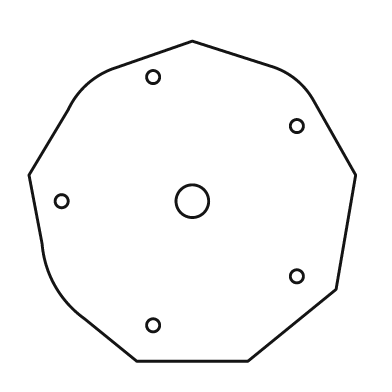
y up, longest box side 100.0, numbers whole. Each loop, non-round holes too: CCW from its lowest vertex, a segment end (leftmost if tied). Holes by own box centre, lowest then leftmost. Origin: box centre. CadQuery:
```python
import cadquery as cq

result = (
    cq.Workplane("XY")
    .moveTo(-17.0, -49.0)
    .lineTo(17.0, -49.0)
    .lineTo(44.0, -27.0)
    .lineTo(50.0, 8.0)
    .lineTo(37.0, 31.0)
    .threePointArc((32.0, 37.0), (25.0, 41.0))
    .lineTo(0.0, 49.0)
    .lineTo(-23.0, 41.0)
    .threePointArc((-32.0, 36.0), (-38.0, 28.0))
    .lineTo(-50.0, 8.0)
    .lineTo(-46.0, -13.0)
    .threePointArc((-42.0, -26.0), (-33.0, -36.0))
    .close()
    .moveTo(-12.0, -38.0)
    .circle(2.0)
    .moveTo(32.0, -23.0)
    .circle(2.0)
    .moveTo(-40.0, 0.0)
    .circle(2.0)
    .moveTo(0.0, 0.0)
    .circle(5.0)
    .moveTo(32.0, 23.0)
    .circle(2.0)
    .moveTo(-12.0, 38.0)
    .circle(2.0)
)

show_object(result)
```